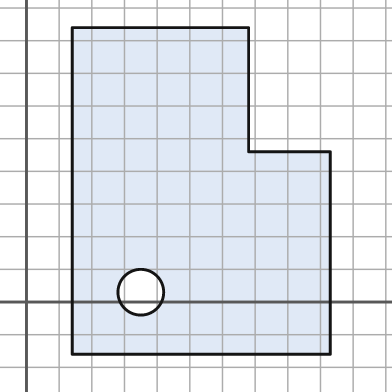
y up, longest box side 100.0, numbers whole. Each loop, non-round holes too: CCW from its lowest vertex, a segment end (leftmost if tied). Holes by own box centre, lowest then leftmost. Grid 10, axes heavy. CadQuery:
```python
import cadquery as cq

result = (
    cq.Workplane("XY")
    .moveTo(14.0, -16.0)
    .lineTo(93.0, -16.0)
    .lineTo(93.0, 46.0)
    .lineTo(68.0, 46.0)
    .lineTo(68.0, 84.0)
    .lineTo(14.0, 84.0)
    .close()
    .moveTo(35.0, 3.0)
    .circle(7.0)
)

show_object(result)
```